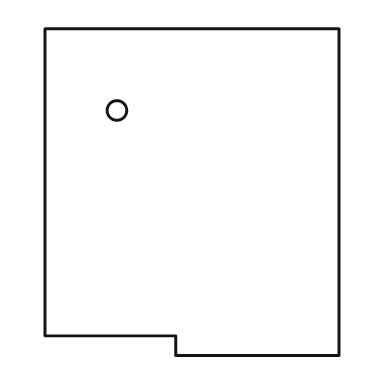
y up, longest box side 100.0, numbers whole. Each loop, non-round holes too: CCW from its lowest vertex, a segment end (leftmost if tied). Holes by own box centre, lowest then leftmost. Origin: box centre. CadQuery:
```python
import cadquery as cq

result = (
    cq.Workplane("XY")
    .moveTo(-5.0, -50.0)
    .lineTo(45.0, -50.0)
    .lineTo(45.0, 50.0)
    .lineTo(-45.0, 50.0)
    .lineTo(-45.0, -44.0)
    .lineTo(-5.0, -44.0)
    .close()
    .moveTo(-23.0, 25.0)
    .circle(3.0)
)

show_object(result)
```